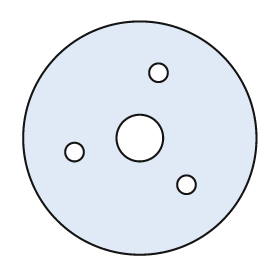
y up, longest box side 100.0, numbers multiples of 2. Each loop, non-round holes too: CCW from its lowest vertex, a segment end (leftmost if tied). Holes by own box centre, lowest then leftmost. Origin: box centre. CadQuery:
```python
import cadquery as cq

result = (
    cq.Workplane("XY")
    .moveTo(0.0, 0.0)
    .circle(50.0)
    .moveTo(20.0, -20.0)
    .circle(4.0)
    .moveTo(-28.0, -6.0)
    .circle(4.0)
    .moveTo(0.0, 0.0)
    .circle(10.0)
    .moveTo(8.0, 28.0)
    .circle(4.0)
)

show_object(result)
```